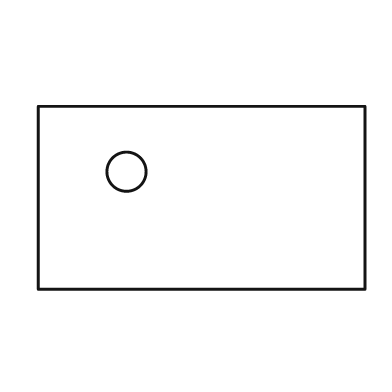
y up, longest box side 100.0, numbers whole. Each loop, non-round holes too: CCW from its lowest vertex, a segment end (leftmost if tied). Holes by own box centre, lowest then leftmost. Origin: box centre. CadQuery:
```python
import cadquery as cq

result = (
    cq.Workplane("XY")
    .moveTo(-50.0, -28.0)
    .lineTo(50.0, -28.0)
    .lineTo(50.0, 28.0)
    .lineTo(-50.0, 28.0)
    .close()
    .moveTo(-23.0, 8.0)
    .circle(6.0)
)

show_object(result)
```